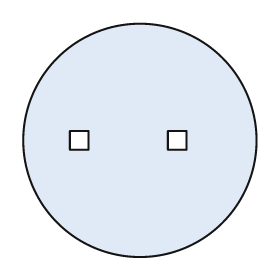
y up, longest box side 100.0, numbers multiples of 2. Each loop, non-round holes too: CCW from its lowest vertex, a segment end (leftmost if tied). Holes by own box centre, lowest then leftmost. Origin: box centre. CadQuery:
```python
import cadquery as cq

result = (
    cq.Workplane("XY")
    .moveTo(0.0, 0.0)
    .circle(50.0)
    .moveTo(-30.0, -4.0)
    .lineTo(-22.0, -4.0)
    .lineTo(-22.0, 4.0)
    .lineTo(-30.0, 4.0)
    .close()
    .moveTo(12.0, -4.0)
    .lineTo(20.0, -4.0)
    .lineTo(20.0, 4.0)
    .lineTo(12.0, 4.0)
    .close()
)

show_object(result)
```